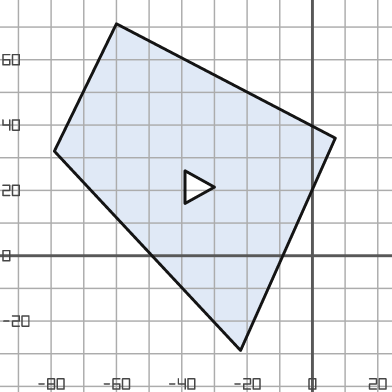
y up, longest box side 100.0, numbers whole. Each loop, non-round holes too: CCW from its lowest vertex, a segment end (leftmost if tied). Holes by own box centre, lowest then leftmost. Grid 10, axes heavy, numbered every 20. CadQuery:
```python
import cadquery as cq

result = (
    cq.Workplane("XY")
    .moveTo(-22.0, -29.0)
    .lineTo(7.0, 36.0)
    .lineTo(-60.0, 71.0)
    .lineTo(-79.0, 32.0)
    .close()
    .moveTo(-39.0, 16.0)
    .lineTo(-30.0, 21.0)
    .lineTo(-39.0, 26.0)
    .close()
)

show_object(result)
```